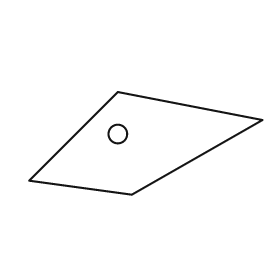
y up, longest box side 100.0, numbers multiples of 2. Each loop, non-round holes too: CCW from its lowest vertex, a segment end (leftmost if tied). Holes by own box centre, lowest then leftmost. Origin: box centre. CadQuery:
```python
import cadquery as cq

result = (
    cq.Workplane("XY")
    .moveTo(-6.0, -22.0)
    .lineTo(50.0, 10.0)
    .lineTo(-12.0, 22.0)
    .lineTo(-50.0, -16.0)
    .close()
    .moveTo(-12.0, 4.0)
    .circle(4.0)
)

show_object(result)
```